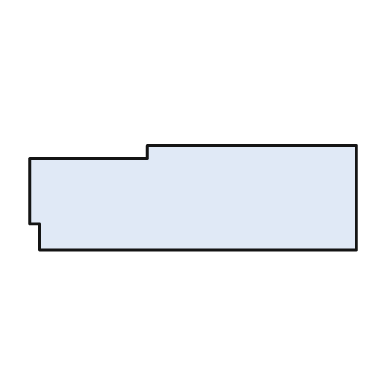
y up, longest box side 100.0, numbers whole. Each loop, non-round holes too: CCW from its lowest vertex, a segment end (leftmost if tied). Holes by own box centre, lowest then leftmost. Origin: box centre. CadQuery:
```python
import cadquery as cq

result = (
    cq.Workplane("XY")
    .moveTo(-47.0, -16.0)
    .lineTo(50.0, -16.0)
    .lineTo(50.0, 16.0)
    .lineTo(-14.0, 16.0)
    .lineTo(-14.0, 12.0)
    .lineTo(-50.0, 12.0)
    .lineTo(-50.0, -8.0)
    .lineTo(-47.0, -8.0)
    .close()
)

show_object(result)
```